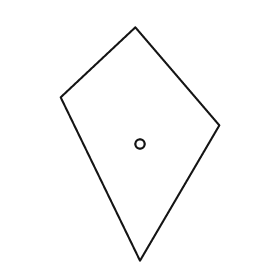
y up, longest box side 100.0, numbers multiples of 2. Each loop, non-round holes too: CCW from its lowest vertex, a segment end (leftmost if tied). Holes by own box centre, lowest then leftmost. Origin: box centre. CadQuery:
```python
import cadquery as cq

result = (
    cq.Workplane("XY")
    .moveTo(0.0, -50.0)
    .lineTo(34.0, 8.0)
    .lineTo(-2.0, 50.0)
    .lineTo(-34.0, 20.0)
    .close()
    .moveTo(0.0, 0.0)
    .circle(2.0)
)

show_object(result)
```